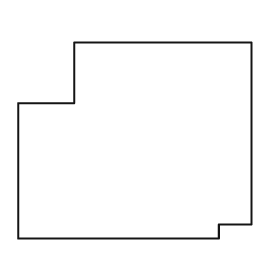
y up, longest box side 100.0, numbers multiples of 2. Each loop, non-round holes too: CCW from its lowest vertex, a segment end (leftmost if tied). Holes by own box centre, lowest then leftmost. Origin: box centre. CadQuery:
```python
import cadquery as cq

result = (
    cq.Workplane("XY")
    .moveTo(-50.0, -42.0)
    .lineTo(36.0, -42.0)
    .lineTo(36.0, -36.0)
    .lineTo(50.0, -36.0)
    .lineTo(50.0, 42.0)
    .lineTo(-26.0, 42.0)
    .lineTo(-26.0, 16.0)
    .lineTo(-50.0, 16.0)
    .close()
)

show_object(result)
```